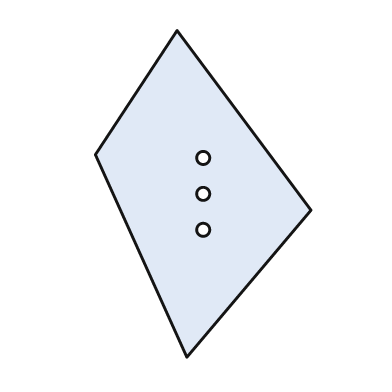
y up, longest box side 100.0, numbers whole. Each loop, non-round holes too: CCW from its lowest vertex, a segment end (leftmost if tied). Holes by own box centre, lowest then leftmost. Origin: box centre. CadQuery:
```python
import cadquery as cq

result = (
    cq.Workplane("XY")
    .moveTo(-5.0, -50.0)
    .lineTo(33.0, -5.0)
    .lineTo(-8.0, 50.0)
    .lineTo(-33.0, 12.0)
    .close()
    .moveTo(0.0, -11.0)
    .circle(2.0)
    .moveTo(0.0, 0.0)
    .circle(2.0)
    .moveTo(0.0, 11.0)
    .circle(2.0)
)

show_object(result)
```